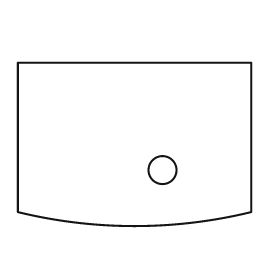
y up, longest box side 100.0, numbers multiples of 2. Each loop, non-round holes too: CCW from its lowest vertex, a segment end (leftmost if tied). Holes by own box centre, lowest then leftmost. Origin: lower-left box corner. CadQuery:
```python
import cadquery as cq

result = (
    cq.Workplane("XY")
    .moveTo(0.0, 6.0)
    .threePointArc((50.0, 0.0), (100.0, 6.0))
    .lineTo(100.0, 70.0)
    .lineTo(0.0, 70.0)
    .close()
    .moveTo(62.0, 24.0)
    .circle(6.0)
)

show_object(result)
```